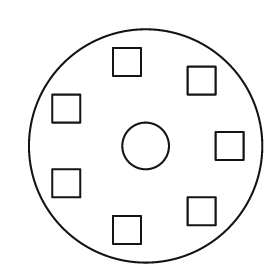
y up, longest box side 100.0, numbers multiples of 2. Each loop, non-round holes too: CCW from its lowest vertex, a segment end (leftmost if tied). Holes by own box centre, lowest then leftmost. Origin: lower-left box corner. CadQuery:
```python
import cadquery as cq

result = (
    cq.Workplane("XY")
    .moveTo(50.0, 50.0)
    .circle(50.0)
    .moveTo(36.0, 8.0)
    .lineTo(48.0, 8.0)
    .lineTo(48.0, 20.0)
    .lineTo(36.0, 20.0)
    .close()
    .moveTo(68.0, 16.0)
    .lineTo(80.0, 16.0)
    .lineTo(80.0, 28.0)
    .lineTo(68.0, 28.0)
    .close()
    .moveTo(10.0, 28.0)
    .lineTo(22.0, 28.0)
    .lineTo(22.0, 40.0)
    .lineTo(10.0, 40.0)
    .close()
    .moveTo(50.0, 50.0)
    .circle(10.0)
    .moveTo(80.0, 44.0)
    .lineTo(92.0, 44.0)
    .lineTo(92.0, 56.0)
    .lineTo(80.0, 56.0)
    .close()
    .moveTo(10.0, 60.0)
    .lineTo(22.0, 60.0)
    .lineTo(22.0, 72.0)
    .lineTo(10.0, 72.0)
    .close()
    .moveTo(68.0, 72.0)
    .lineTo(80.0, 72.0)
    .lineTo(80.0, 84.0)
    .lineTo(68.0, 84.0)
    .close()
    .moveTo(36.0, 80.0)
    .lineTo(48.0, 80.0)
    .lineTo(48.0, 92.0)
    .lineTo(36.0, 92.0)
    .close()
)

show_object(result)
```